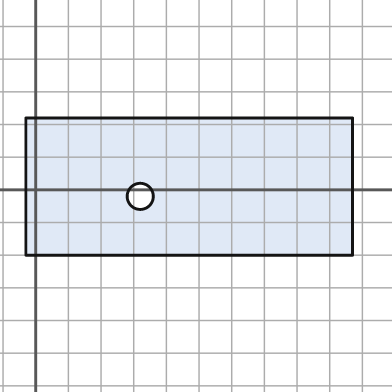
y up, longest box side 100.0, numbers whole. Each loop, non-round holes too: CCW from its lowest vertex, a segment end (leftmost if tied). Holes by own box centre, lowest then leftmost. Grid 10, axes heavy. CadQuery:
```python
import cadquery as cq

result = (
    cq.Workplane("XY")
    .moveTo(-3.0, -20.0)
    .lineTo(97.0, -20.0)
    .lineTo(97.0, 22.0)
    .lineTo(-3.0, 22.0)
    .close()
    .moveTo(32.0, -2.0)
    .circle(4.0)
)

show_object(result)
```